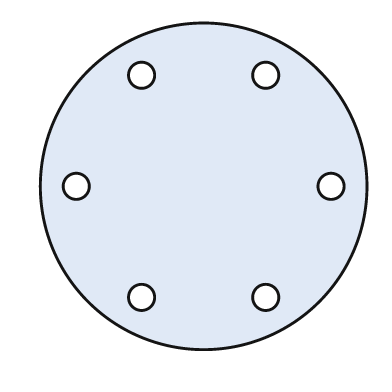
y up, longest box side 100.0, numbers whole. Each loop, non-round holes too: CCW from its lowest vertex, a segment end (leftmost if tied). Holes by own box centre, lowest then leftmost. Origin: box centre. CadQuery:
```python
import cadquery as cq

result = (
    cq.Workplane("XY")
    .moveTo(0.0, 0.0)
    .circle(50.0)
    .moveTo(-19.0, -34.0)
    .circle(4.0)
    .moveTo(19.0, -34.0)
    .circle(4.0)
    .moveTo(-39.0, 0.0)
    .circle(4.0)
    .moveTo(39.0, 0.0)
    .circle(4.0)
    .moveTo(-19.0, 34.0)
    .circle(4.0)
    .moveTo(19.0, 34.0)
    .circle(4.0)
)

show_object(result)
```